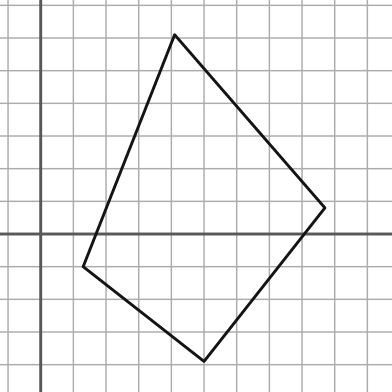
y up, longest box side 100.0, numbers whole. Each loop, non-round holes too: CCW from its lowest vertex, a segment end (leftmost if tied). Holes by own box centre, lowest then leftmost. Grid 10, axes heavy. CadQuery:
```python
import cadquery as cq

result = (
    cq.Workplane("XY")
    .moveTo(50.0, -39.0)
    .lineTo(87.0, 8.0)
    .lineTo(41.0, 61.0)
    .lineTo(13.0, -10.0)
    .close()
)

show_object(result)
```